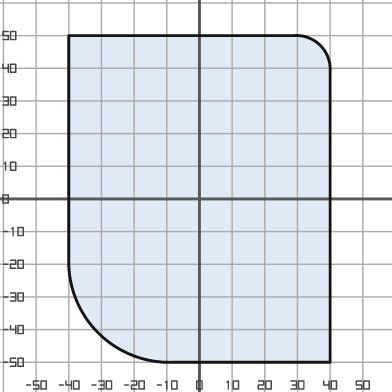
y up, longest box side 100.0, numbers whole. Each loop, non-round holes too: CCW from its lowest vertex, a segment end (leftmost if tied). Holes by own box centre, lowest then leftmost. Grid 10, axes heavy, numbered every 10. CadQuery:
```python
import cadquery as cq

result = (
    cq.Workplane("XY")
    .moveTo(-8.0, -50.0)
    .lineTo(40.0, -50.0)
    .lineTo(40.0, 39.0)
    .threePointArc((37.0, 47.0), (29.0, 50.0))
    .lineTo(-40.0, 50.0)
    .lineTo(-40.0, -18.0)
    .threePointArc((-31.0, -41.0), (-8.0, -50.0))
    .close()
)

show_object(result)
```